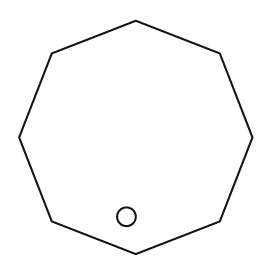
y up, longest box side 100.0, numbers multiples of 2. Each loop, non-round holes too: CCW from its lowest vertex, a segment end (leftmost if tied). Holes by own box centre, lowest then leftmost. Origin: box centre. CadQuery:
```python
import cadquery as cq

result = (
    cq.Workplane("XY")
    .moveTo(0.0, -50.0)
    .lineTo(36.0, -36.0)
    .lineTo(50.0, 0.0)
    .lineTo(36.0, 36.0)
    .lineTo(0.0, 50.0)
    .lineTo(-36.0, 36.0)
    .lineTo(-50.0, 0.0)
    .lineTo(-36.0, -36.0)
    .close()
    .moveTo(-4.0, -34.0)
    .circle(4.0)
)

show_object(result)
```